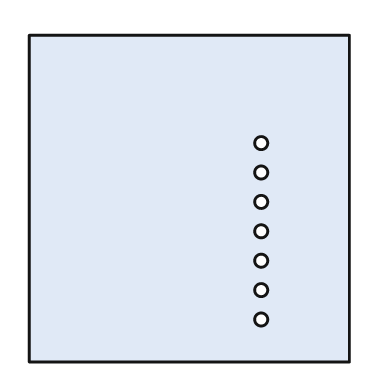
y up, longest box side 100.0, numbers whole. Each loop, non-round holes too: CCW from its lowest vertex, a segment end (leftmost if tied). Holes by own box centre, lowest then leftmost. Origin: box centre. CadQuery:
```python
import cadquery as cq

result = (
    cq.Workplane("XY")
    .moveTo(-49.0, -50.0)
    .lineTo(49.0, -50.0)
    .lineTo(49.0, 50.0)
    .lineTo(-49.0, 50.0)
    .close()
    .moveTo(22.0, -37.0)
    .circle(2.0)
    .moveTo(22.0, -28.0)
    .circle(2.0)
    .moveTo(22.0, -19.0)
    .circle(2.0)
    .moveTo(22.0, -10.0)
    .circle(2.0)
    .moveTo(22.0, -1.0)
    .circle(2.0)
    .moveTo(22.0, 8.0)
    .circle(2.0)
    .moveTo(22.0, 17.0)
    .circle(2.0)
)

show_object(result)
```